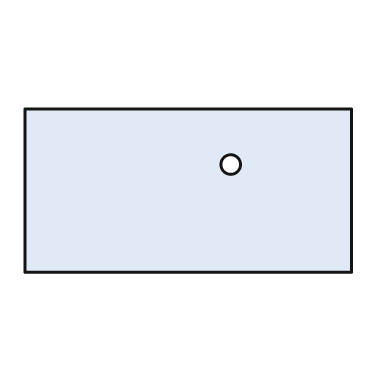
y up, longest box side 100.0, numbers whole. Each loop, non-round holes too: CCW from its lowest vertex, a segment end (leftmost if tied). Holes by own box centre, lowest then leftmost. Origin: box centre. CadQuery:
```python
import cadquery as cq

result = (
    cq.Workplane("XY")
    .moveTo(-50.0, -25.0)
    .lineTo(50.0, -25.0)
    .lineTo(50.0, 25.0)
    .lineTo(-50.0, 25.0)
    .close()
    .moveTo(13.0, 8.0)
    .circle(3.0)
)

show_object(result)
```